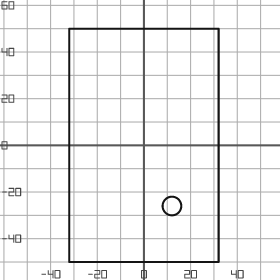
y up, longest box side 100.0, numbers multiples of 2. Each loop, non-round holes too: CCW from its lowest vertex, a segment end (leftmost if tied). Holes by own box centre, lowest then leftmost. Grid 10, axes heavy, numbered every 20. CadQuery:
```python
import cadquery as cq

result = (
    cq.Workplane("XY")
    .moveTo(-32.0, -50.0)
    .lineTo(32.0, -50.0)
    .lineTo(32.0, 50.0)
    .lineTo(-32.0, 50.0)
    .close()
    .moveTo(12.0, -26.0)
    .circle(4.0)
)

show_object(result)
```